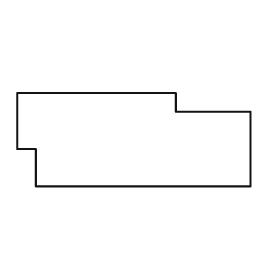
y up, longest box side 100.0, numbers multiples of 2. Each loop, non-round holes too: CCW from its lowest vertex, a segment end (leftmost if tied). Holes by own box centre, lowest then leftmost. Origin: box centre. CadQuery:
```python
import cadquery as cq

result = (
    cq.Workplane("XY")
    .moveTo(-42.0, -20.0)
    .lineTo(50.0, -20.0)
    .lineTo(50.0, 12.0)
    .lineTo(18.0, 12.0)
    .lineTo(18.0, 20.0)
    .lineTo(-50.0, 20.0)
    .lineTo(-50.0, -4.0)
    .lineTo(-42.0, -4.0)
    .close()
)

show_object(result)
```